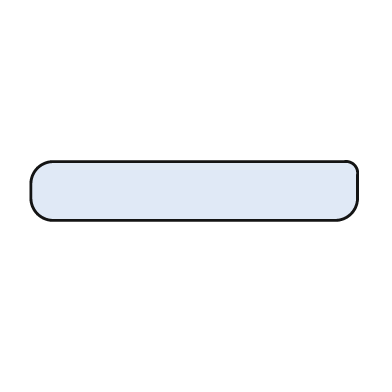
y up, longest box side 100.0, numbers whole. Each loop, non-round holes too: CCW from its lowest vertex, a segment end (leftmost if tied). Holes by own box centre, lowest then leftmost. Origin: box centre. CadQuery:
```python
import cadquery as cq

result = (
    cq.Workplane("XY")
    .moveTo(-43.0, -9.0)
    .lineTo(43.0, -9.0)
    .threePointArc((48.0, -7.0), (50.0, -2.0))
    .lineTo(50.0, 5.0)
    .threePointArc((49.0, 8.0), (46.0, 9.0))
    .lineTo(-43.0, 9.0)
    .threePointArc((-48.0, 7.0), (-50.0, 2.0))
    .lineTo(-50.0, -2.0)
    .threePointArc((-48.0, -7.0), (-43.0, -9.0))
    .close()
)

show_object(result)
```